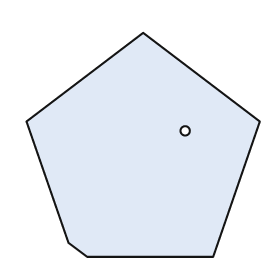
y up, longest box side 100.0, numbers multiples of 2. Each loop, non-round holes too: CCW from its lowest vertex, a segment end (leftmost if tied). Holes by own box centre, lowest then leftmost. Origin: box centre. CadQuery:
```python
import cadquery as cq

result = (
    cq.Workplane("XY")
    .moveTo(-24.0, -48.0)
    .lineTo(30.0, -48.0)
    .lineTo(50.0, 10.0)
    .lineTo(0.0, 48.0)
    .lineTo(-50.0, 10.0)
    .lineTo(-32.0, -42.0)
    .close()
    .moveTo(18.0, 6.0)
    .circle(2.0)
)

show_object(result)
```